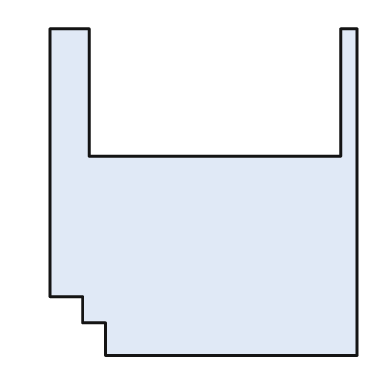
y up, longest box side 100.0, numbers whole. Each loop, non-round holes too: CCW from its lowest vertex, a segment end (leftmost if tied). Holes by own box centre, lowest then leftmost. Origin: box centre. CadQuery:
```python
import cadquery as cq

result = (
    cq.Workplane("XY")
    .moveTo(-30.0, -50.0)
    .lineTo(47.0, -50.0)
    .lineTo(47.0, 50.0)
    .lineTo(42.0, 50.0)
    .lineTo(42.0, 11.0)
    .lineTo(-35.0, 11.0)
    .lineTo(-35.0, 50.0)
    .lineTo(-47.0, 50.0)
    .lineTo(-47.0, -32.0)
    .lineTo(-37.0, -32.0)
    .lineTo(-37.0, -40.0)
    .lineTo(-30.0, -40.0)
    .close()
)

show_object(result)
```